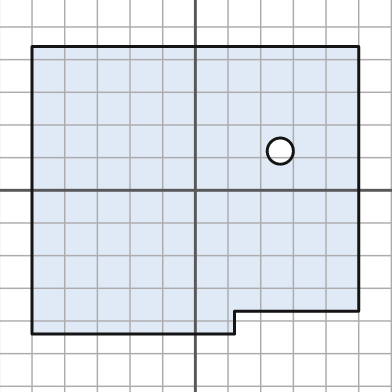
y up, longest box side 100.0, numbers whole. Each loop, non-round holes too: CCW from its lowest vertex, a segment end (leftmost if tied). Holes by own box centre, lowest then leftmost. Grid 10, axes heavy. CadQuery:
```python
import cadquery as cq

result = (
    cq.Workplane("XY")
    .moveTo(-50.0, -44.0)
    .lineTo(12.0, -44.0)
    .lineTo(12.0, -37.0)
    .lineTo(50.0, -37.0)
    .lineTo(50.0, 44.0)
    .lineTo(-50.0, 44.0)
    .close()
    .moveTo(26.0, 12.0)
    .circle(4.0)
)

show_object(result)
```